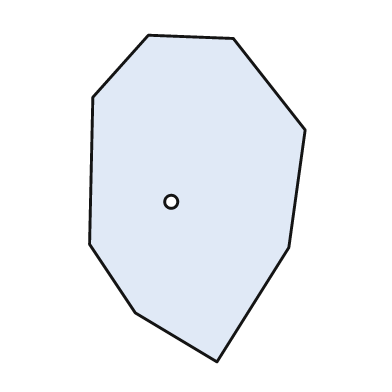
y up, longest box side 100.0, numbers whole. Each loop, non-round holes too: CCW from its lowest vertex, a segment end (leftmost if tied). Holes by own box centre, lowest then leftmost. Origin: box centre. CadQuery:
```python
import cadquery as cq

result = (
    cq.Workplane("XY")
    .moveTo(6.0, -50.0)
    .lineTo(28.0, -15.0)
    .lineTo(33.0, 21.0)
    .lineTo(11.0, 49.0)
    .lineTo(-15.0, 50.0)
    .lineTo(-32.0, 31.0)
    .lineTo(-33.0, -14.0)
    .lineTo(-19.0, -35.0)
    .close()
    .moveTo(-8.0, -1.0)
    .circle(2.0)
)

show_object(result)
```